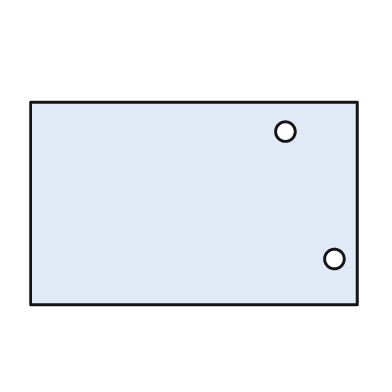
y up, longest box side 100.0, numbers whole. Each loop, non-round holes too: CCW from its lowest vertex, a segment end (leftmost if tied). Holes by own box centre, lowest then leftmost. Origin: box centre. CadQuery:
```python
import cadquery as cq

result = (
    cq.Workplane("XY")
    .moveTo(-50.0, -31.0)
    .lineTo(50.0, -31.0)
    .lineTo(50.0, 31.0)
    .lineTo(-50.0, 31.0)
    .close()
    .moveTo(43.0, -17.0)
    .circle(3.0)
    .moveTo(28.0, 22.0)
    .circle(3.0)
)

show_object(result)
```